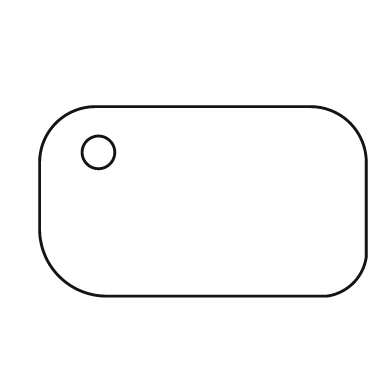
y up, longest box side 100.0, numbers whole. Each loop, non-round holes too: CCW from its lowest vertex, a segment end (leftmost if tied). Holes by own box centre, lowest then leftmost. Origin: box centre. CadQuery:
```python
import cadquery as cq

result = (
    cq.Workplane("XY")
    .moveTo(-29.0, -29.0)
    .lineTo(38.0, -29.0)
    .threePointArc((46.0, -25.0), (50.0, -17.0))
    .lineTo(50.0, 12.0)
    .threePointArc((45.0, 24.0), (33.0, 29.0))
    .lineTo(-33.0, 29.0)
    .threePointArc((-45.0, 24.0), (-50.0, 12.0))
    .lineTo(-50.0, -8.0)
    .threePointArc((-44.0, -23.0), (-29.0, -29.0))
    .close()
    .moveTo(-32.0, 15.0)
    .circle(5.0)
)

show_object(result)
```